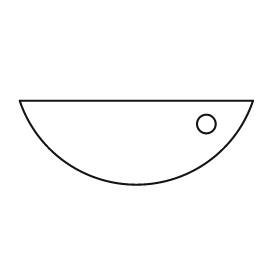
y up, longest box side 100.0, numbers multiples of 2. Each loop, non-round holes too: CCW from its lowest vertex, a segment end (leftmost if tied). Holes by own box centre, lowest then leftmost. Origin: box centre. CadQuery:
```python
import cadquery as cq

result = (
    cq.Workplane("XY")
    .moveTo(-50.0, 18.0)
    .threePointArc((0.0, -18.0), (50.0, 18.0))
    .close()
    .moveTo(30.0, 8.0)
    .circle(4.0)
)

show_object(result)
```